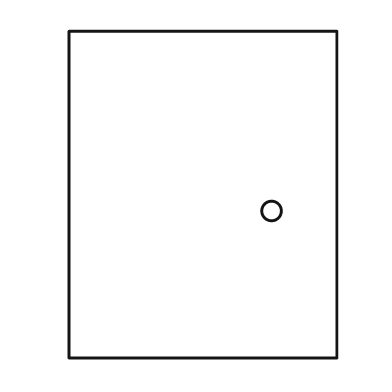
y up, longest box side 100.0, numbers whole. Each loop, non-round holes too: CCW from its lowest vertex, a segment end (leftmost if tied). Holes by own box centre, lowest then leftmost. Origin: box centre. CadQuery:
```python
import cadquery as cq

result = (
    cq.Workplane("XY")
    .moveTo(-41.0, -50.0)
    .lineTo(41.0, -50.0)
    .lineTo(41.0, 50.0)
    .lineTo(-41.0, 50.0)
    .close()
    .moveTo(21.0, -5.0)
    .circle(3.0)
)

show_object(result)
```